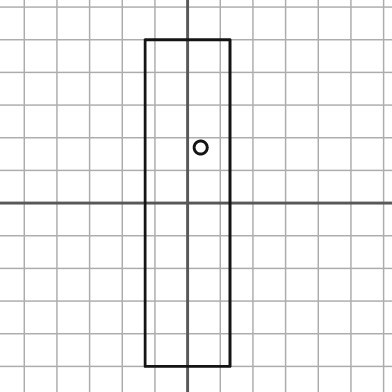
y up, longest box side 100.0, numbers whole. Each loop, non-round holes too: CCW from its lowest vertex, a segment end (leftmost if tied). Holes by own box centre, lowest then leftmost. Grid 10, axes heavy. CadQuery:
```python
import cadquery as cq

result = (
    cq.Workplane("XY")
    .moveTo(-13.0, -50.0)
    .lineTo(13.0, -50.0)
    .lineTo(13.0, 50.0)
    .lineTo(-13.0, 50.0)
    .close()
    .moveTo(4.0, 17.0)
    .circle(2.0)
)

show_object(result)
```